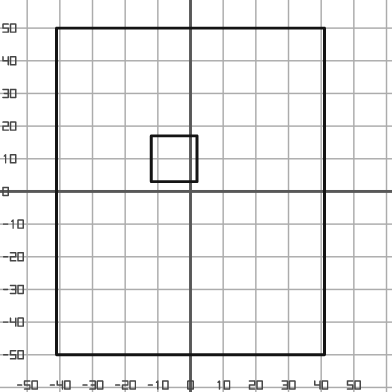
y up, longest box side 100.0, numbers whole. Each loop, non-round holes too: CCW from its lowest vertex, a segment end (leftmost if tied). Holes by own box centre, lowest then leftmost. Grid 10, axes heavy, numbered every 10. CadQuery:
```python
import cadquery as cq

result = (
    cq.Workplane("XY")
    .moveTo(-41.0, -50.0)
    .lineTo(41.0, -50.0)
    .lineTo(41.0, 50.0)
    .lineTo(-41.0, 50.0)
    .close()
    .moveTo(-12.0, 3.0)
    .lineTo(2.0, 3.0)
    .lineTo(2.0, 17.0)
    .lineTo(-12.0, 17.0)
    .close()
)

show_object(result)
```